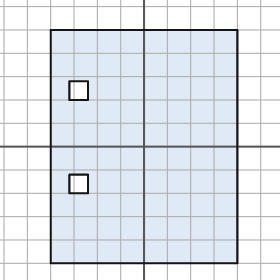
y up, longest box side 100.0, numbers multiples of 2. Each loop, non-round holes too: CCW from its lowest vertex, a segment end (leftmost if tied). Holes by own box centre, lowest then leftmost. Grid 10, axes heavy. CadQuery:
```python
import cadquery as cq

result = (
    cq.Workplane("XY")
    .moveTo(-40.0, -50.0)
    .lineTo(40.0, -50.0)
    .lineTo(40.0, 50.0)
    .lineTo(-40.0, 50.0)
    .close()
    .moveTo(-32.0, -20.0)
    .lineTo(-24.0, -20.0)
    .lineTo(-24.0, -12.0)
    .lineTo(-32.0, -12.0)
    .close()
    .moveTo(-32.0, 20.0)
    .lineTo(-24.0, 20.0)
    .lineTo(-24.0, 28.0)
    .lineTo(-32.0, 28.0)
    .close()
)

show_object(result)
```